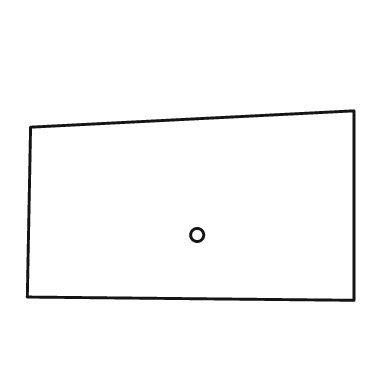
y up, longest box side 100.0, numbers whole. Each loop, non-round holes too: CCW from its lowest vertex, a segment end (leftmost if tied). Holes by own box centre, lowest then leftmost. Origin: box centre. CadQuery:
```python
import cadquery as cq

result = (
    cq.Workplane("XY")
    .moveTo(50.0, -29.0)
    .lineTo(50.0, 29.0)
    .lineTo(-49.0, 24.0)
    .lineTo(-50.0, -28.0)
    .close()
    .moveTo(2.0, -9.0)
    .circle(2.0)
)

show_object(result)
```